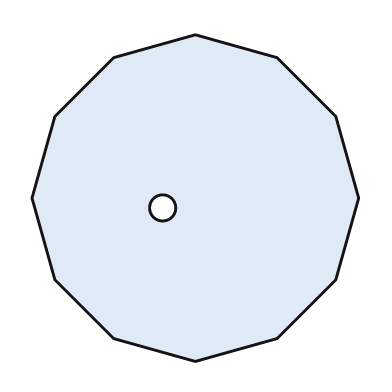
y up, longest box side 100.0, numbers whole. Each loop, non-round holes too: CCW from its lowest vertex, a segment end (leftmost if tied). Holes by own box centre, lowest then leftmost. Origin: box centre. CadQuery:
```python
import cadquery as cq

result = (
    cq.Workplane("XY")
    .moveTo(0.0, -50.0)
    .lineTo(25.0, -43.0)
    .lineTo(43.0, -25.0)
    .lineTo(50.0, 0.0)
    .lineTo(43.0, 25.0)
    .lineTo(25.0, 43.0)
    .lineTo(0.0, 50.0)
    .lineTo(-25.0, 43.0)
    .lineTo(-43.0, 25.0)
    .lineTo(-50.0, 0.0)
    .lineTo(-43.0, -25.0)
    .lineTo(-25.0, -43.0)
    .close()
    .moveTo(-10.0, -3.0)
    .circle(4.0)
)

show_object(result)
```